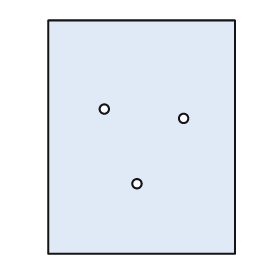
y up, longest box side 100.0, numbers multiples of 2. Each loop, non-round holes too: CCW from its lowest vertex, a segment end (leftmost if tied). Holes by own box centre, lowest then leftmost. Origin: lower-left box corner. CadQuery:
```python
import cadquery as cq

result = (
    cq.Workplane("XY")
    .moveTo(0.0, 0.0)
    .lineTo(80.0, 0.0)
    .lineTo(80.0, 100.0)
    .lineTo(0.0, 100.0)
    .close()
    .moveTo(38.0, 30.0)
    .circle(2.0)
    .moveTo(58.0, 58.0)
    .circle(2.0)
    .moveTo(24.0, 62.0)
    .circle(2.0)
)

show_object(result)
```